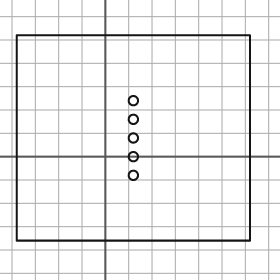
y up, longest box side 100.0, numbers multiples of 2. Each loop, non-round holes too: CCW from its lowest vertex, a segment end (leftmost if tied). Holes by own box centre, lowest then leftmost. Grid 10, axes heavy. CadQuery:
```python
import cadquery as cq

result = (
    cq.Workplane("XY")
    .moveTo(-38.0, -36.0)
    .lineTo(62.0, -36.0)
    .lineTo(62.0, 52.0)
    .lineTo(-38.0, 52.0)
    .close()
    .moveTo(12.0, -8.0)
    .circle(2.0)
    .moveTo(12.0, 0.0)
    .circle(2.0)
    .moveTo(12.0, 8.0)
    .circle(2.0)
    .moveTo(12.0, 16.0)
    .circle(2.0)
    .moveTo(12.0, 24.0)
    .circle(2.0)
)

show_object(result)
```